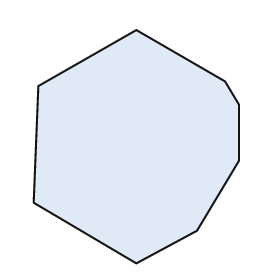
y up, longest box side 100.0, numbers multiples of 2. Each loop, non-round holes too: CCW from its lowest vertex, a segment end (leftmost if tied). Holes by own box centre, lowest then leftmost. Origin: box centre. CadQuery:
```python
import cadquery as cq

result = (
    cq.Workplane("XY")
    .moveTo(0.0, -50.0)
    .lineTo(26.0, -36.0)
    .lineTo(44.0, -6.0)
    .lineTo(44.0, 18.0)
    .lineTo(38.0, 28.0)
    .lineTo(0.0, 50.0)
    .lineTo(-42.0, 26.0)
    .lineTo(-44.0, -24.0)
    .close()
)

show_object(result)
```